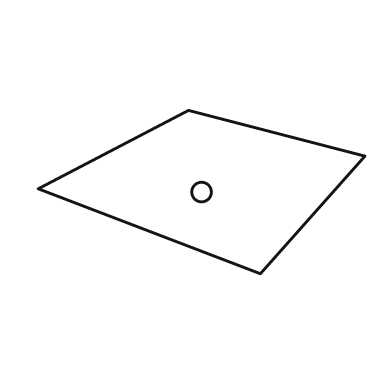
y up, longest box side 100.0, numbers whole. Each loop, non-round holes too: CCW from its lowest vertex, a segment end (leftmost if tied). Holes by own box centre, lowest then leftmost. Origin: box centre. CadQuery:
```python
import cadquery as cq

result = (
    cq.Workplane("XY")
    .moveTo(18.0, -25.0)
    .lineTo(50.0, 11.0)
    .lineTo(-4.0, 25.0)
    .lineTo(-50.0, 1.0)
    .close()
    .moveTo(0.0, 0.0)
    .circle(3.0)
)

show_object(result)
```